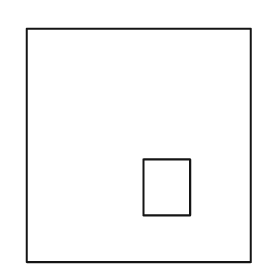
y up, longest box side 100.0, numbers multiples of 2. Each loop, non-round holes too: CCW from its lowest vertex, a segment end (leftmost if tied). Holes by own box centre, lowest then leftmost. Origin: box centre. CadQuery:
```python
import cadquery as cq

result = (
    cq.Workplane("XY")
    .moveTo(-48.0, -50.0)
    .lineTo(48.0, -50.0)
    .lineTo(48.0, 50.0)
    .lineTo(-48.0, 50.0)
    .close()
    .moveTo(2.0, -30.0)
    .lineTo(22.0, -30.0)
    .lineTo(22.0, -6.0)
    .lineTo(2.0, -6.0)
    .close()
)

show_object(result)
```